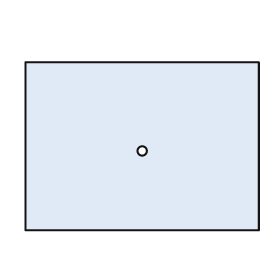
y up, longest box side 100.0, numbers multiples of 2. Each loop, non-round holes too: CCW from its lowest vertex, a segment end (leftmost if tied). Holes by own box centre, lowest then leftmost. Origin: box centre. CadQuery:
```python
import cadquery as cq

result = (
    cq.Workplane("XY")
    .moveTo(-50.0, -36.0)
    .lineTo(50.0, -36.0)
    .lineTo(50.0, 36.0)
    .lineTo(-50.0, 36.0)
    .close()
    .moveTo(0.0, -2.0)
    .circle(2.0)
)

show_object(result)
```